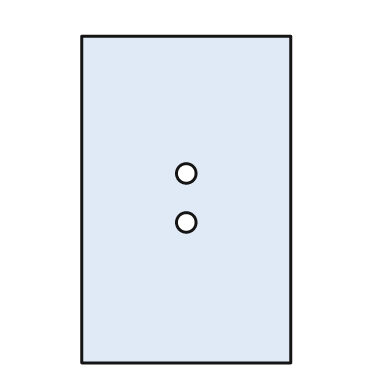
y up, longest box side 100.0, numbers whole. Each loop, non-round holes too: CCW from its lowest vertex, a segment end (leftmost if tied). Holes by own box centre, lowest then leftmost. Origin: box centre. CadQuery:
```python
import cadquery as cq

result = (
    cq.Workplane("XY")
    .moveTo(-32.0, -50.0)
    .lineTo(32.0, -50.0)
    .lineTo(32.0, 50.0)
    .lineTo(-32.0, 50.0)
    .close()
    .moveTo(0.0, -7.0)
    .circle(3.0)
    .moveTo(0.0, 8.0)
    .circle(3.0)
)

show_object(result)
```